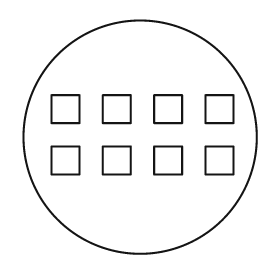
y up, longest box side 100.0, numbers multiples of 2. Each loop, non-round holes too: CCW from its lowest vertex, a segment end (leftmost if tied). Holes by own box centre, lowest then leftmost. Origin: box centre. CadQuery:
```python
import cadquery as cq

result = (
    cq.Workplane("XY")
    .moveTo(0.0, 0.0)
    .circle(50.0)
    .moveTo(-38.0, -16.0)
    .lineTo(-26.0, -16.0)
    .lineTo(-26.0, -4.0)
    .lineTo(-38.0, -4.0)
    .close()
    .moveTo(-16.0, -16.0)
    .lineTo(-4.0, -16.0)
    .lineTo(-4.0, -4.0)
    .lineTo(-16.0, -4.0)
    .close()
    .moveTo(6.0, -16.0)
    .lineTo(18.0, -16.0)
    .lineTo(18.0, -4.0)
    .lineTo(6.0, -4.0)
    .close()
    .moveTo(28.0, -16.0)
    .lineTo(40.0, -16.0)
    .lineTo(40.0, -4.0)
    .lineTo(28.0, -4.0)
    .close()
    .moveTo(-38.0, 6.0)
    .lineTo(-26.0, 6.0)
    .lineTo(-26.0, 18.0)
    .lineTo(-38.0, 18.0)
    .close()
    .moveTo(-16.0, 6.0)
    .lineTo(-4.0, 6.0)
    .lineTo(-4.0, 18.0)
    .lineTo(-16.0, 18.0)
    .close()
    .moveTo(6.0, 6.0)
    .lineTo(18.0, 6.0)
    .lineTo(18.0, 18.0)
    .lineTo(6.0, 18.0)
    .close()
    .moveTo(28.0, 6.0)
    .lineTo(40.0, 6.0)
    .lineTo(40.0, 18.0)
    .lineTo(28.0, 18.0)
    .close()
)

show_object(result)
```